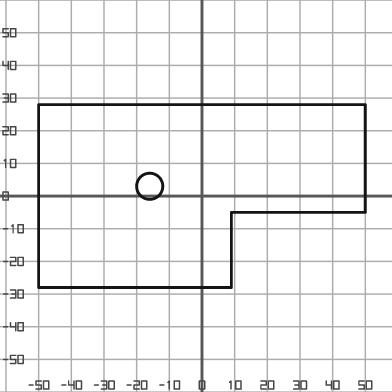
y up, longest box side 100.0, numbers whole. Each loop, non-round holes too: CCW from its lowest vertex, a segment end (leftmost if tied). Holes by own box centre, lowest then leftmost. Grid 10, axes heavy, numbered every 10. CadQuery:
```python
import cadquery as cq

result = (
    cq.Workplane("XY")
    .moveTo(-50.0, -28.0)
    .lineTo(9.0, -28.0)
    .lineTo(9.0, -5.0)
    .lineTo(50.0, -5.0)
    .lineTo(50.0, 28.0)
    .lineTo(-50.0, 28.0)
    .close()
    .moveTo(-16.0, 3.0)
    .circle(4.0)
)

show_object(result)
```